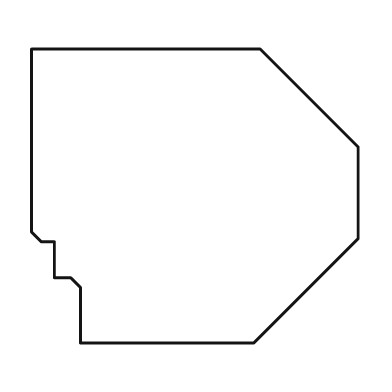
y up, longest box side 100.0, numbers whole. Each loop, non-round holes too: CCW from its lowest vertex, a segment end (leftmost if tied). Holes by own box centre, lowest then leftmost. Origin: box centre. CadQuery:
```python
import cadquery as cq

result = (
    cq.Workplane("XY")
    .moveTo(-35.0, -45.0)
    .lineTo(18.0, -45.0)
    .lineTo(50.0, -13.0)
    .lineTo(50.0, 15.0)
    .lineTo(20.0, 45.0)
    .lineTo(-50.0, 45.0)
    .lineTo(-50.0, -11.0)
    .lineTo(-47.0, -14.0)
    .lineTo(-43.0, -14.0)
    .lineTo(-43.0, -25.0)
    .lineTo(-38.0, -25.0)
    .lineTo(-35.0, -28.0)
    .close()
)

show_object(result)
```